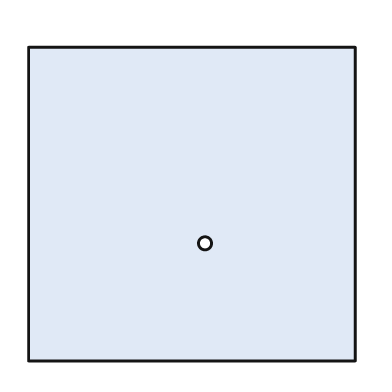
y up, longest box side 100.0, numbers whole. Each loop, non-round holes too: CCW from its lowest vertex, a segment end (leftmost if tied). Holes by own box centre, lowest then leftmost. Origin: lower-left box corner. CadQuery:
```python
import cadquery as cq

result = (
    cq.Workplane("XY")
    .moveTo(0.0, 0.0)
    .lineTo(100.0, 0.0)
    .lineTo(100.0, 96.0)
    .lineTo(0.0, 96.0)
    .close()
    .moveTo(54.0, 36.0)
    .circle(2.0)
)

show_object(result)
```